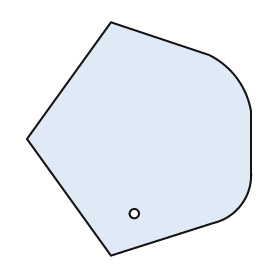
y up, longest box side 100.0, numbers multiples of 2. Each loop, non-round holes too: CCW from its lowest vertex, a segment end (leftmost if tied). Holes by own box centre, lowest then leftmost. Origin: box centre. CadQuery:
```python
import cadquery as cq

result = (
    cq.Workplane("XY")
    .moveTo(-12.0, -50.0)
    .lineTo(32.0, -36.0)
    .threePointArc((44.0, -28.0), (48.0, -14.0))
    .lineTo(48.0, 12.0)
    .threePointArc((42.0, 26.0), (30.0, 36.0))
    .lineTo(-12.0, 50.0)
    .lineTo(-48.0, 0.0)
    .close()
    .moveTo(-2.0, -32.0)
    .circle(2.0)
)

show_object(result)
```